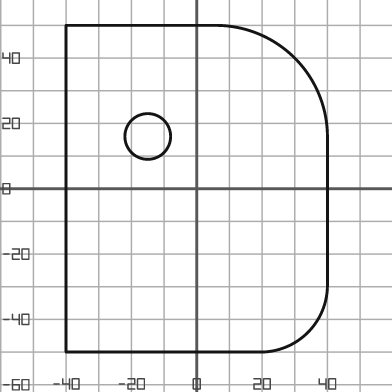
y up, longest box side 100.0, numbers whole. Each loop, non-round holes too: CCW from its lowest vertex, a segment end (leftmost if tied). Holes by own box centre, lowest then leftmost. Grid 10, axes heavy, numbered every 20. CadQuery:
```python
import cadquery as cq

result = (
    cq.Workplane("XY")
    .moveTo(-40.0, -50.0)
    .lineTo(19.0, -50.0)
    .threePointArc((34.0, -44.0), (40.0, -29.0))
    .lineTo(40.0, 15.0)
    .threePointArc((30.0, 40.0), (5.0, 50.0))
    .lineTo(-40.0, 50.0)
    .close()
    .moveTo(-15.0, 16.0)
    .circle(7.0)
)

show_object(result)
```